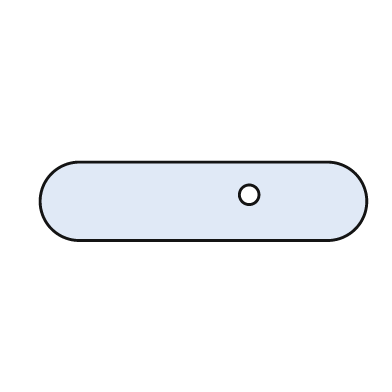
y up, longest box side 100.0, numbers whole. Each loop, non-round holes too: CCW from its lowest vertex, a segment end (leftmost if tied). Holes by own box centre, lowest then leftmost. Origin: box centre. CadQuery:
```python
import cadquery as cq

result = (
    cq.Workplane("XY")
    .moveTo(-38.0, -12.0)
    .lineTo(38.0, -12.0)
    .threePointArc((50.0, 0.0), (38.0, 12.0))
    .lineTo(-38.0, 12.0)
    .threePointArc((-50.0, 0.0), (-38.0, -12.0))
    .close()
    .moveTo(14.0, 2.0)
    .circle(3.0)
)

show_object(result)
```